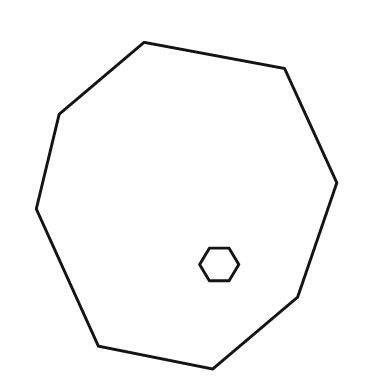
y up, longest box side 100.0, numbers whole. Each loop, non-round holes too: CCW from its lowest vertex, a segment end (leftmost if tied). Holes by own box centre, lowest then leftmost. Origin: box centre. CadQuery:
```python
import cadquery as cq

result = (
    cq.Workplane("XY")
    .moveTo(8.0, -50.0)
    .lineTo(34.0, -28.0)
    .lineTo(46.0, 7.0)
    .lineTo(30.0, 42.0)
    .lineTo(-13.0, 50.0)
    .lineTo(-39.0, 28.0)
    .lineTo(-46.0, -1.0)
    .lineTo(-27.0, -43.0)
    .close()
    .moveTo(7.0, -23.0)
    .lineTo(13.0, -23.0)
    .lineTo(16.0, -18.0)
    .lineTo(13.0, -13.0)
    .lineTo(7.0, -13.0)
    .lineTo(4.0, -18.0)
    .close()
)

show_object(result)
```